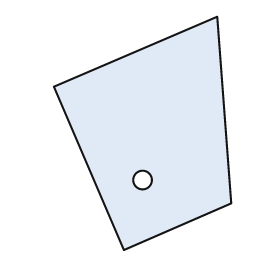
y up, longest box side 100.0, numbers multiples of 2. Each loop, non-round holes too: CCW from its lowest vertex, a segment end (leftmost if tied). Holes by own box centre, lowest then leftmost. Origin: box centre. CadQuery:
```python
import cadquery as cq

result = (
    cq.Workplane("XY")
    .moveTo(-8.0, -50.0)
    .lineTo(38.0, -30.0)
    .lineTo(32.0, 50.0)
    .lineTo(-38.0, 20.0)
    .close()
    .moveTo(0.0, -20.0)
    .circle(4.0)
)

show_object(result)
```